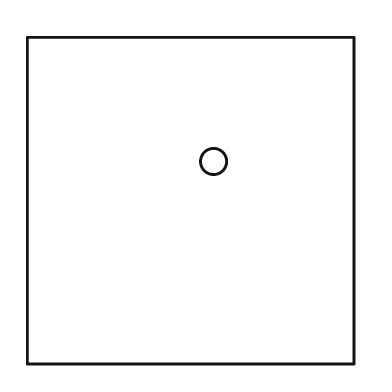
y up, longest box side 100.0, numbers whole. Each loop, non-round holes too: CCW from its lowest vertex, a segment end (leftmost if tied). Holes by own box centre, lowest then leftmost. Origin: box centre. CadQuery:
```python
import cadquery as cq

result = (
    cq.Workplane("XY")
    .moveTo(-50.0, -50.0)
    .lineTo(50.0, -50.0)
    .lineTo(50.0, 50.0)
    .lineTo(-50.0, 50.0)
    .close()
    .moveTo(7.0, 12.0)
    .circle(4.0)
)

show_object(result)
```